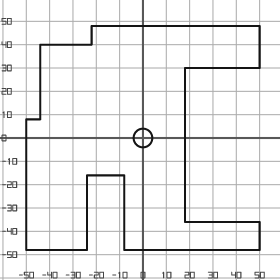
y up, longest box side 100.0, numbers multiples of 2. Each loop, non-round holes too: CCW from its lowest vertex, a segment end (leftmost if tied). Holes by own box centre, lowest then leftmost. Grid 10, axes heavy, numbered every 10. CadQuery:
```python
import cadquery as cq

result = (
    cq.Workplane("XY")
    .moveTo(-50.0, -48.0)
    .lineTo(-24.0, -48.0)
    .lineTo(-24.0, -16.0)
    .lineTo(-8.0, -16.0)
    .lineTo(-8.0, -48.0)
    .lineTo(50.0, -48.0)
    .lineTo(50.0, -36.0)
    .lineTo(18.0, -36.0)
    .lineTo(18.0, 30.0)
    .lineTo(50.0, 30.0)
    .lineTo(50.0, 48.0)
    .lineTo(-22.0, 48.0)
    .lineTo(-22.0, 40.0)
    .lineTo(-44.0, 40.0)
    .lineTo(-44.0, 8.0)
    .lineTo(-50.0, 8.0)
    .close()
    .moveTo(0.0, 0.0)
    .circle(4.0)
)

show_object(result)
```